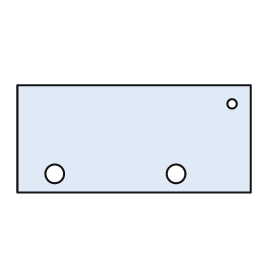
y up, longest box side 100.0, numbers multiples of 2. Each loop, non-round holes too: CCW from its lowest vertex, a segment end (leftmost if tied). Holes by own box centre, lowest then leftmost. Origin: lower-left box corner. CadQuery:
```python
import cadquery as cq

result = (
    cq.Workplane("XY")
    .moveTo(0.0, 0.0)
    .lineTo(100.0, 0.0)
    .lineTo(100.0, 46.0)
    .lineTo(0.0, 46.0)
    .close()
    .moveTo(16.0, 8.0)
    .circle(4.0)
    .moveTo(68.0, 8.0)
    .circle(4.0)
    .moveTo(92.0, 38.0)
    .circle(2.0)
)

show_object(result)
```